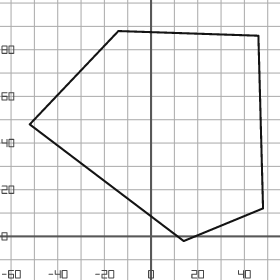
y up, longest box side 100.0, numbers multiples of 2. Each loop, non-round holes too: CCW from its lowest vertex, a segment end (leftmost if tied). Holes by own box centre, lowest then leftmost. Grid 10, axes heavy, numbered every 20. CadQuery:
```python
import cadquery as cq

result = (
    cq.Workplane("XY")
    .moveTo(14.0, -2.0)
    .lineTo(48.0, 12.0)
    .lineTo(46.0, 86.0)
    .lineTo(-14.0, 88.0)
    .lineTo(-52.0, 48.0)
    .close()
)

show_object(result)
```